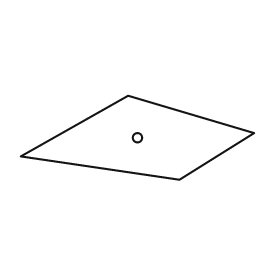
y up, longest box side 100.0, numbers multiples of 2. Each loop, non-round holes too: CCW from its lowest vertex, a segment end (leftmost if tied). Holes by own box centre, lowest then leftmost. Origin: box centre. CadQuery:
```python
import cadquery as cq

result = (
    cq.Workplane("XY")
    .moveTo(18.0, -18.0)
    .lineTo(50.0, 2.0)
    .lineTo(-4.0, 18.0)
    .lineTo(-50.0, -8.0)
    .close()
    .moveTo(0.0, 0.0)
    .circle(2.0)
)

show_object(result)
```